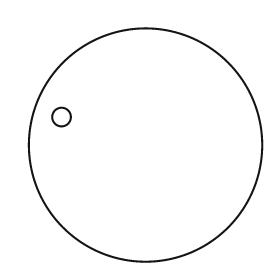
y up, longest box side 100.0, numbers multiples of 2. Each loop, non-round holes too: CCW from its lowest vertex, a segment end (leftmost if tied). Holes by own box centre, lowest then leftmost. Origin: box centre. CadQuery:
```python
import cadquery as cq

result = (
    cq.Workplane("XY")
    .moveTo(0.0, 0.0)
    .circle(50.0)
    .moveTo(-36.0, 12.0)
    .circle(4.0)
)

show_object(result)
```